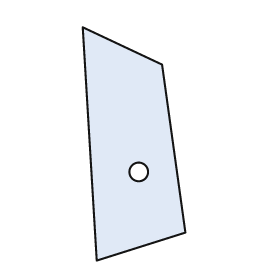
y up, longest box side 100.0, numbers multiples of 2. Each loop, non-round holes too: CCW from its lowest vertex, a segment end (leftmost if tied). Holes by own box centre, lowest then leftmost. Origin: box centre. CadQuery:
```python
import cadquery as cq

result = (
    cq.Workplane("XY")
    .moveTo(-16.0, -50.0)
    .lineTo(22.0, -38.0)
    .lineTo(12.0, 34.0)
    .lineTo(-22.0, 50.0)
    .close()
    .moveTo(2.0, -12.0)
    .circle(4.0)
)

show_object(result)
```